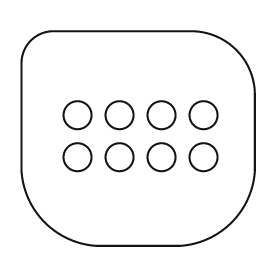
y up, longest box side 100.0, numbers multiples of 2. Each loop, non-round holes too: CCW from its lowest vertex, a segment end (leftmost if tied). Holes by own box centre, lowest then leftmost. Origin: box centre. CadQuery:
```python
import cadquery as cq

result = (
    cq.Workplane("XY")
    .moveTo(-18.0, -46.0)
    .lineTo(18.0, -46.0)
    .threePointArc((40.0, -36.0), (50.0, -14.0))
    .lineTo(50.0, 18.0)
    .threePointArc((42.0, 38.0), (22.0, 46.0))
    .lineTo(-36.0, 46.0)
    .threePointArc((-46.0, 42.0), (-50.0, 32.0))
    .lineTo(-50.0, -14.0)
    .threePointArc((-40.0, -36.0), (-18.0, -46.0))
    .close()
    .moveTo(-26.0, -8.0)
    .circle(6.0)
    .moveTo(-8.0, -8.0)
    .circle(6.0)
    .moveTo(10.0, -8.0)
    .circle(6.0)
    .moveTo(28.0, -8.0)
    .circle(6.0)
    .moveTo(-26.0, 10.0)
    .circle(6.0)
    .moveTo(-8.0, 10.0)
    .circle(6.0)
    .moveTo(10.0, 10.0)
    .circle(6.0)
    .moveTo(28.0, 10.0)
    .circle(6.0)
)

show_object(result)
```